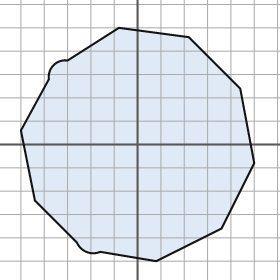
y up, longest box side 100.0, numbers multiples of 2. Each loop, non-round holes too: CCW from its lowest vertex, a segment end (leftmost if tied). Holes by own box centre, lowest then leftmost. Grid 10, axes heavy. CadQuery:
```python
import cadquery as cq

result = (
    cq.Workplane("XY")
    .moveTo(8.0, -50.0)
    .lineTo(36.0, -36.0)
    .lineTo(50.0, -8.0)
    .lineTo(44.0, 24.0)
    .lineTo(22.0, 46.0)
    .lineTo(-8.0, 50.0)
    .lineTo(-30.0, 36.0)
    .threePointArc((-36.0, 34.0), (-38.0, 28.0))
    .lineTo(-50.0, 6.0)
    .lineTo(-44.0, -24.0)
    .lineTo(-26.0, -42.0)
    .threePointArc((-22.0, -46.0), (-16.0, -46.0))
    .close()
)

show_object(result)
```